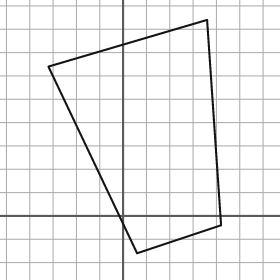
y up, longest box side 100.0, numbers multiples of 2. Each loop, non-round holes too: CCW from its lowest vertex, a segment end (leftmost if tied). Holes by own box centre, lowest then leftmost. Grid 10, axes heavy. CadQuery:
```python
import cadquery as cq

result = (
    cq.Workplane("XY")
    .moveTo(6.0, -16.0)
    .lineTo(42.0, -4.0)
    .lineTo(36.0, 84.0)
    .lineTo(-32.0, 64.0)
    .close()
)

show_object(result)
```